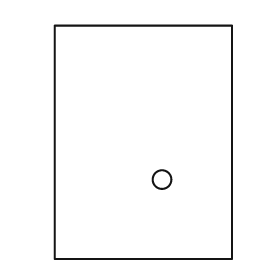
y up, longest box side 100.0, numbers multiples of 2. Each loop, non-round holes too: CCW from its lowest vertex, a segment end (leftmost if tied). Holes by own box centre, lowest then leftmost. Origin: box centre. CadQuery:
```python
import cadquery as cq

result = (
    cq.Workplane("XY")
    .moveTo(-38.0, -50.0)
    .lineTo(38.0, -50.0)
    .lineTo(38.0, 50.0)
    .lineTo(-38.0, 50.0)
    .close()
    .moveTo(8.0, -16.0)
    .circle(4.0)
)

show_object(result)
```